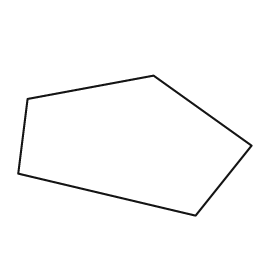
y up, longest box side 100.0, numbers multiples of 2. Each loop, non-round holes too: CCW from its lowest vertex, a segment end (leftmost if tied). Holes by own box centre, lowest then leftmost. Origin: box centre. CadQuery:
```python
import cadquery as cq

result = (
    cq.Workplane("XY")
    .moveTo(26.0, -30.0)
    .lineTo(50.0, 0.0)
    .lineTo(8.0, 30.0)
    .lineTo(-46.0, 20.0)
    .lineTo(-50.0, -12.0)
    .close()
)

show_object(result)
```